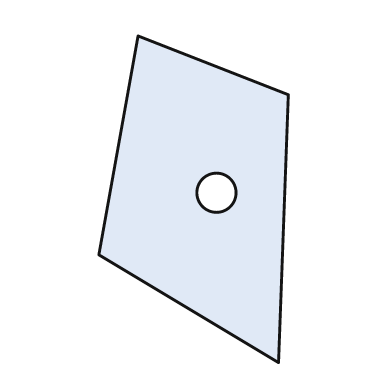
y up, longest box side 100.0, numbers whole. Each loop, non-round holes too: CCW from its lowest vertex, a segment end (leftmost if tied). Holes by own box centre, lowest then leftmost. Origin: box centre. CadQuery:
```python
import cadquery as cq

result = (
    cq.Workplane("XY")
    .moveTo(26.0, -50.0)
    .lineTo(29.0, 32.0)
    .lineTo(-17.0, 50.0)
    .lineTo(-29.0, -17.0)
    .close()
    .moveTo(7.0, 2.0)
    .circle(6.0)
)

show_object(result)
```